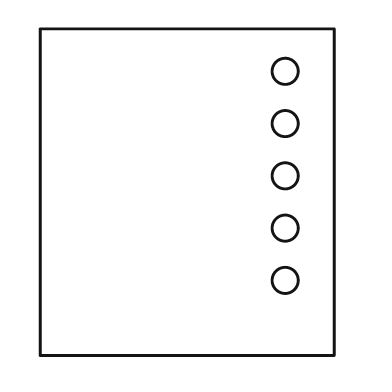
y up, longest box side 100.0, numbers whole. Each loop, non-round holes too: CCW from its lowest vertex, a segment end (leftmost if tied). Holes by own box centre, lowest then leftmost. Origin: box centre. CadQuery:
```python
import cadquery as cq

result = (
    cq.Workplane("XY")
    .moveTo(-45.0, -50.0)
    .lineTo(45.0, -50.0)
    .lineTo(45.0, 50.0)
    .lineTo(-45.0, 50.0)
    .close()
    .moveTo(30.0, -27.0)
    .circle(4.0)
    .moveTo(30.0, -11.0)
    .circle(4.0)
    .moveTo(30.0, 5.0)
    .circle(4.0)
    .moveTo(30.0, 21.0)
    .circle(4.0)
    .moveTo(30.0, 37.0)
    .circle(4.0)
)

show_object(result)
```